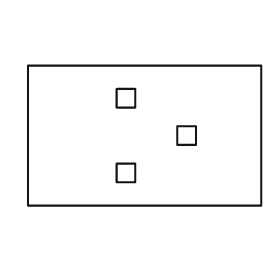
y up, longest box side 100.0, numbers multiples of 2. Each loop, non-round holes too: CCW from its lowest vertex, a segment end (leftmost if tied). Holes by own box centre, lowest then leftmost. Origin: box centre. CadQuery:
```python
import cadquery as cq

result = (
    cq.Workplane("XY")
    .moveTo(-50.0, -30.0)
    .lineTo(50.0, -30.0)
    .lineTo(50.0, 30.0)
    .lineTo(-50.0, 30.0)
    .close()
    .moveTo(-12.0, -20.0)
    .lineTo(-4.0, -20.0)
    .lineTo(-4.0, -12.0)
    .lineTo(-12.0, -12.0)
    .close()
    .moveTo(14.0, -4.0)
    .lineTo(22.0, -4.0)
    .lineTo(22.0, 4.0)
    .lineTo(14.0, 4.0)
    .close()
    .moveTo(-12.0, 12.0)
    .lineTo(-4.0, 12.0)
    .lineTo(-4.0, 20.0)
    .lineTo(-12.0, 20.0)
    .close()
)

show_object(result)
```